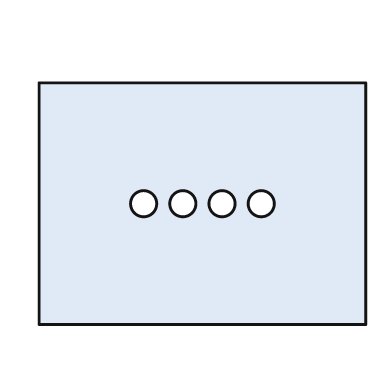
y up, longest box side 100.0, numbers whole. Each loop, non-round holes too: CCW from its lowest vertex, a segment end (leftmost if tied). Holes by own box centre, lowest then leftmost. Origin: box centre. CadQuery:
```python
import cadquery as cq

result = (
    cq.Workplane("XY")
    .moveTo(-50.0, -37.0)
    .lineTo(50.0, -37.0)
    .lineTo(50.0, 37.0)
    .lineTo(-50.0, 37.0)
    .close()
    .moveTo(-18.0, 0.0)
    .circle(4.0)
    .moveTo(-6.0, 0.0)
    .circle(4.0)
    .moveTo(6.0, 0.0)
    .circle(4.0)
    .moveTo(18.0, 0.0)
    .circle(4.0)
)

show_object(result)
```